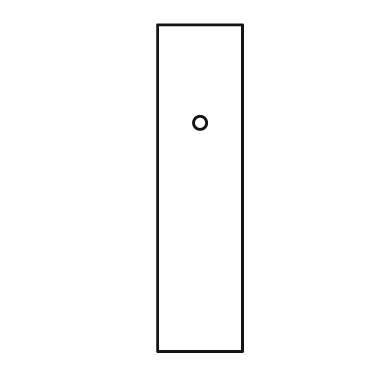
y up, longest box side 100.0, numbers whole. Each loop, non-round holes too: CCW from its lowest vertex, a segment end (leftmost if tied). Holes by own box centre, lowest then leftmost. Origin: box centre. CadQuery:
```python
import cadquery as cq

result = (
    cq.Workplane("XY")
    .moveTo(-13.0, -50.0)
    .lineTo(13.0, -50.0)
    .lineTo(13.0, 50.0)
    .lineTo(-13.0, 50.0)
    .close()
    .moveTo(0.0, 20.0)
    .circle(2.0)
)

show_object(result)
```